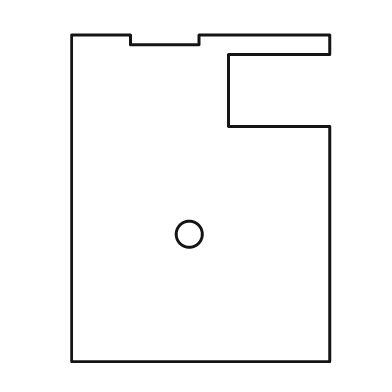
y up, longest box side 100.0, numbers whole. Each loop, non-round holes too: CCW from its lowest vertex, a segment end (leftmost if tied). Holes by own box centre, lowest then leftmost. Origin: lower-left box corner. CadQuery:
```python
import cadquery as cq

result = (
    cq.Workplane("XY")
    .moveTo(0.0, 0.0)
    .lineTo(79.0, 0.0)
    .lineTo(79.0, 72.0)
    .lineTo(48.0, 72.0)
    .lineTo(48.0, 94.0)
    .lineTo(79.0, 94.0)
    .lineTo(79.0, 100.0)
    .lineTo(39.0, 100.0)
    .lineTo(39.0, 97.0)
    .lineTo(18.0, 97.0)
    .lineTo(18.0, 100.0)
    .lineTo(0.0, 100.0)
    .close()
    .moveTo(36.0, 39.0)
    .circle(4.0)
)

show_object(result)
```